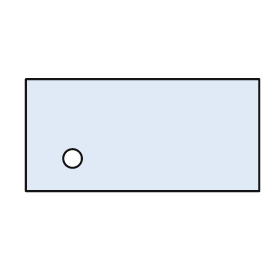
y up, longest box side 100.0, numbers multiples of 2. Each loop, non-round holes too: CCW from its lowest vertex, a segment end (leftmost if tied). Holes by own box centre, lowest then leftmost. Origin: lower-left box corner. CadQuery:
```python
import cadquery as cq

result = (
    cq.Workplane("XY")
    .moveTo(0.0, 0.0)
    .lineTo(100.0, 0.0)
    .lineTo(100.0, 48.0)
    .lineTo(0.0, 48.0)
    .close()
    .moveTo(20.0, 14.0)
    .circle(4.0)
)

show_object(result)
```